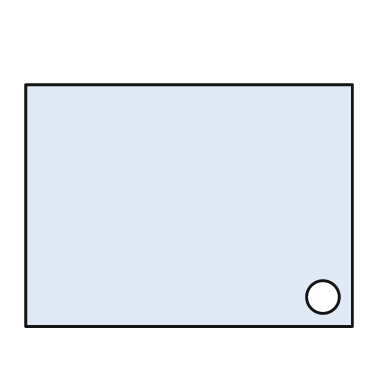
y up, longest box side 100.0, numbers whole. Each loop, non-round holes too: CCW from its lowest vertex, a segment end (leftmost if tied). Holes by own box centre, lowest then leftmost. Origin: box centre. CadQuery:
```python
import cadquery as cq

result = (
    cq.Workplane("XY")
    .moveTo(-50.0, -37.0)
    .lineTo(50.0, -37.0)
    .lineTo(50.0, 37.0)
    .lineTo(-50.0, 37.0)
    .close()
    .moveTo(41.0, -28.0)
    .circle(5.0)
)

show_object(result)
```